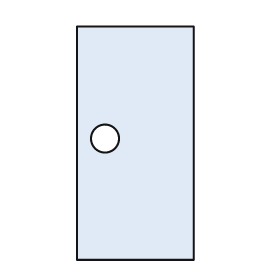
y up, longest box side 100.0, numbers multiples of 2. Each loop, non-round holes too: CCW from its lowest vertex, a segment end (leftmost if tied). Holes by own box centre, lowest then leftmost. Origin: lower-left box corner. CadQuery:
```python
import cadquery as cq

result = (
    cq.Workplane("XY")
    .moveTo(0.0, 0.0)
    .lineTo(50.0, 0.0)
    .lineTo(50.0, 100.0)
    .lineTo(0.0, 100.0)
    .close()
    .moveTo(12.0, 52.0)
    .circle(6.0)
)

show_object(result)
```